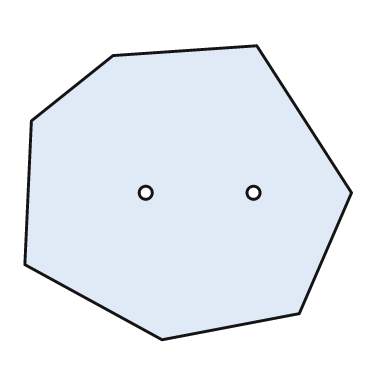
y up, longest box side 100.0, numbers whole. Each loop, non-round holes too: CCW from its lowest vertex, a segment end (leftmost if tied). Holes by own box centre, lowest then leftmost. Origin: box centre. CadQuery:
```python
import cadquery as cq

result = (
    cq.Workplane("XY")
    .moveTo(-8.0, -45.0)
    .lineTo(34.0, -37.0)
    .lineTo(50.0, 0.0)
    .lineTo(21.0, 45.0)
    .lineTo(-23.0, 42.0)
    .lineTo(-48.0, 22.0)
    .lineTo(-50.0, -22.0)
    .close()
    .moveTo(-13.0, 0.0)
    .circle(2.0)
    .moveTo(20.0, 0.0)
    .circle(2.0)
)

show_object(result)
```